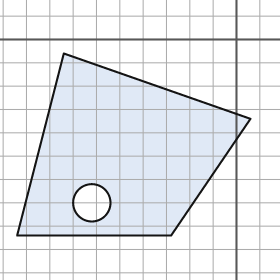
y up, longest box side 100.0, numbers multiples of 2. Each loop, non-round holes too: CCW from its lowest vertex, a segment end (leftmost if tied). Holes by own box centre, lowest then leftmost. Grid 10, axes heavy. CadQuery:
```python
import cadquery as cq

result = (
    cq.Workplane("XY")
    .moveTo(-94.0, -84.0)
    .lineTo(-28.0, -84.0)
    .lineTo(6.0, -34.0)
    .lineTo(-74.0, -6.0)
    .close()
    .moveTo(-62.0, -70.0)
    .circle(8.0)
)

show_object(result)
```